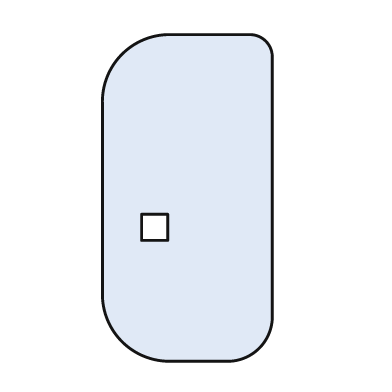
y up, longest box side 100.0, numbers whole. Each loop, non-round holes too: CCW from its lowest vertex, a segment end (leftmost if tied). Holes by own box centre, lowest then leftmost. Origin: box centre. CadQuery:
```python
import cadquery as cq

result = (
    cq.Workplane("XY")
    .moveTo(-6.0, -50.0)
    .lineTo(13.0, -50.0)
    .threePointArc((22.0, -46.0), (26.0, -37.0))
    .lineTo(26.0, 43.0)
    .threePointArc((24.0, 48.0), (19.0, 50.0))
    .lineTo(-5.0, 50.0)
    .threePointArc((-20.0, 44.0), (-26.0, 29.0))
    .lineTo(-26.0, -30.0)
    .threePointArc((-20.0, -44.0), (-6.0, -50.0))
    .close()
    .moveTo(-14.0, -13.0)
    .lineTo(-6.0, -13.0)
    .lineTo(-6.0, -5.0)
    .lineTo(-14.0, -5.0)
    .close()
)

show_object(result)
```